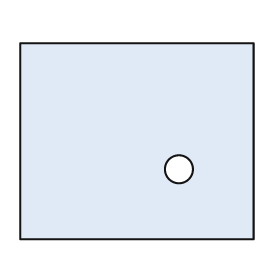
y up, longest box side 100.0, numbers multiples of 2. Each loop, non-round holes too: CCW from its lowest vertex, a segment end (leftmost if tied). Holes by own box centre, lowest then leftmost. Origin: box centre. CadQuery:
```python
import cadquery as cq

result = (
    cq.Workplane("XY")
    .moveTo(-50.0, -42.0)
    .lineTo(50.0, -42.0)
    .lineTo(50.0, 42.0)
    .lineTo(-50.0, 42.0)
    .close()
    .moveTo(18.0, -12.0)
    .circle(6.0)
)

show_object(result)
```